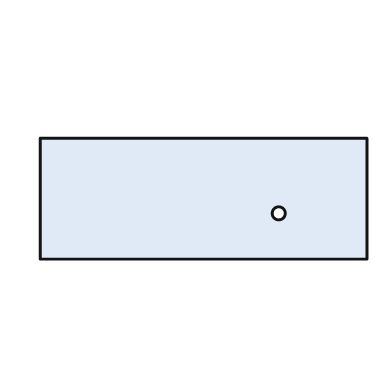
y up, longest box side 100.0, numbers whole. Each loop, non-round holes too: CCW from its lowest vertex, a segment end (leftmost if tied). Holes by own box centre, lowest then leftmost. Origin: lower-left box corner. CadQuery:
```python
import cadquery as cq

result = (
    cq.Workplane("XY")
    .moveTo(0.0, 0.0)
    .lineTo(100.0, 0.0)
    .lineTo(100.0, 37.0)
    .lineTo(0.0, 37.0)
    .close()
    .moveTo(73.0, 14.0)
    .circle(2.0)
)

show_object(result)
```